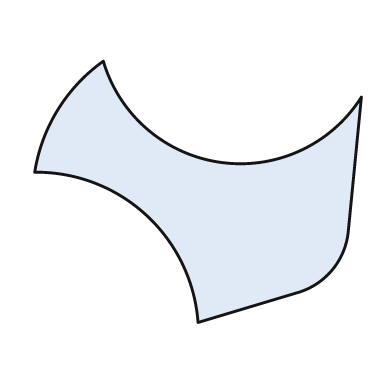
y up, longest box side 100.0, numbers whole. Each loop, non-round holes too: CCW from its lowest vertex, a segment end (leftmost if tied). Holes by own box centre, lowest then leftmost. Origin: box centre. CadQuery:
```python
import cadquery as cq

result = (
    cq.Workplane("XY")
    .moveTo(0.0, -40.0)
    .lineTo(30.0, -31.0)
    .threePointArc((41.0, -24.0), (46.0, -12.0))
    .lineTo(50.0, 29.0)
    .threePointArc((7.0, 9.0), (-29.0, 40.0))
    .threePointArc((-43.0, 25.0), (-50.0, 6.0))
    .threePointArc((-16.0, -7.0), (0.0, -40.0))
    .close()
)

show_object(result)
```